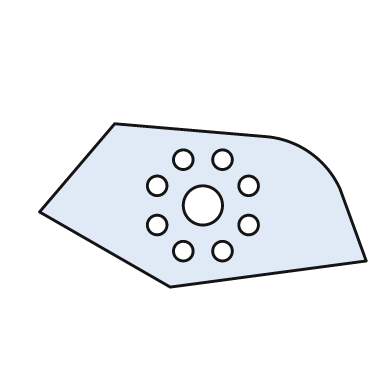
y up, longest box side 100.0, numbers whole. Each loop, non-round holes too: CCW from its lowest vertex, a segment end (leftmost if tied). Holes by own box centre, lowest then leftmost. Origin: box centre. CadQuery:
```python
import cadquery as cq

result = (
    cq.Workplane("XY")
    .moveTo(-10.0, -25.0)
    .lineTo(50.0, -17.0)
    .lineTo(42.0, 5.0)
    .threePointArc((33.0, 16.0), (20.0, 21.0))
    .lineTo(-27.0, 25.0)
    .lineTo(-50.0, -2.0)
    .close()
    .moveTo(-6.0, -14.0)
    .circle(3.0)
    .moveTo(6.0, -14.0)
    .circle(3.0)
    .moveTo(-14.0, -6.0)
    .circle(3.0)
    .moveTo(14.0, -6.0)
    .circle(3.0)
    .moveTo(0.0, 0.0)
    .circle(6.0)
    .moveTo(-14.0, 6.0)
    .circle(3.0)
    .moveTo(14.0, 6.0)
    .circle(3.0)
    .moveTo(-6.0, 14.0)
    .circle(3.0)
    .moveTo(6.0, 14.0)
    .circle(3.0)
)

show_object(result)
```